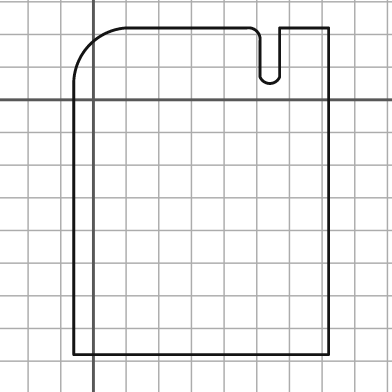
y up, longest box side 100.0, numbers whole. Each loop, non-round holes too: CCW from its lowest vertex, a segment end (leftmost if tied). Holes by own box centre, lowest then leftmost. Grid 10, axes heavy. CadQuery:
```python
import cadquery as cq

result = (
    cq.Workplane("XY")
    .moveTo(-6.0, -78.0)
    .lineTo(72.0, -78.0)
    .lineTo(72.0, 22.0)
    .lineTo(57.0, 22.0)
    .lineTo(57.0, 7.0)
    .threePointArc((54.0, 5.0), (51.0, 7.0))
    .lineTo(51.0, 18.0)
    .threePointArc((50.0, 21.0), (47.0, 22.0))
    .lineTo(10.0, 22.0)
    .threePointArc((-1.0, 17.0), (-6.0, 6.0))
    .close()
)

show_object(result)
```